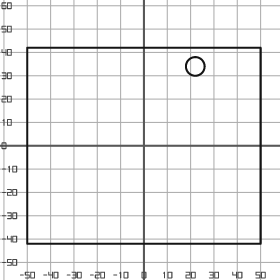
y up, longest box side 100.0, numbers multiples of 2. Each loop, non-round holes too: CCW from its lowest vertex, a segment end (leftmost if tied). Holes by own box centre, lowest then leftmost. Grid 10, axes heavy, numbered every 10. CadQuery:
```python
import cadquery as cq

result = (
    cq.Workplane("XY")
    .moveTo(-50.0, -42.0)
    .lineTo(50.0, -42.0)
    .lineTo(50.0, 42.0)
    .lineTo(-50.0, 42.0)
    .close()
    .moveTo(22.0, 34.0)
    .circle(4.0)
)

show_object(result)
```